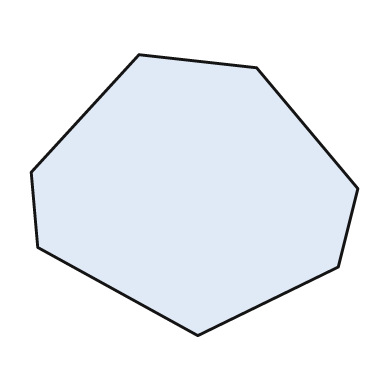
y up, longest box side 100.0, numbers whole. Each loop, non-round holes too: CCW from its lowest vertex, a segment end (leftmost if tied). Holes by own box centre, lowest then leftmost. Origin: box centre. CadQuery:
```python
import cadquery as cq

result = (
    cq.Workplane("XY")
    .moveTo(1.0, -43.0)
    .lineTo(44.0, -22.0)
    .lineTo(50.0, 2.0)
    .lineTo(19.0, 39.0)
    .lineTo(-17.0, 43.0)
    .lineTo(-50.0, 7.0)
    .lineTo(-48.0, -16.0)
    .close()
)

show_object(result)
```